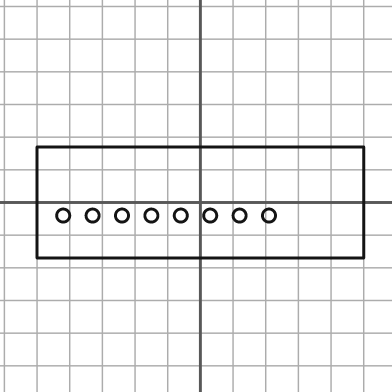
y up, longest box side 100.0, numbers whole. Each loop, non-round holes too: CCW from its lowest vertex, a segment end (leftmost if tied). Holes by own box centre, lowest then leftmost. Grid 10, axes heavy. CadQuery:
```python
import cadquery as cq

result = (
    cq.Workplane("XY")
    .moveTo(-50.0, -17.0)
    .lineTo(50.0, -17.0)
    .lineTo(50.0, 17.0)
    .lineTo(-50.0, 17.0)
    .close()
    .moveTo(-42.0, -4.0)
    .circle(2.0)
    .moveTo(-33.0, -4.0)
    .circle(2.0)
    .moveTo(-24.0, -4.0)
    .circle(2.0)
    .moveTo(-15.0, -4.0)
    .circle(2.0)
    .moveTo(-6.0, -4.0)
    .circle(2.0)
    .moveTo(3.0, -4.0)
    .circle(2.0)
    .moveTo(12.0, -4.0)
    .circle(2.0)
    .moveTo(21.0, -4.0)
    .circle(2.0)
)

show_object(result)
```